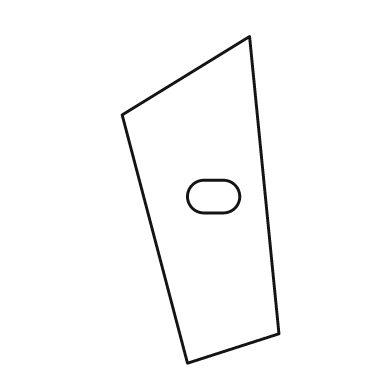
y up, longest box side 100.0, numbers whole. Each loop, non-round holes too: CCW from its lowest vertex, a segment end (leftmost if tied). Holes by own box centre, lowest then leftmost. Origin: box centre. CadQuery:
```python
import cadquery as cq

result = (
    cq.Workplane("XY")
    .moveTo(-4.0, -50.0)
    .lineTo(24.0, -41.0)
    .lineTo(15.0, 50.0)
    .lineTo(-24.0, 26.0)
    .close()
    .moveTo(1.0, -4.0)
    .lineTo(7.0, -4.0)
    .threePointArc((12.0, 1.0), (7.0, 6.0))
    .lineTo(1.0, 6.0)
    .threePointArc((-4.0, 1.0), (1.0, -4.0))
    .close()
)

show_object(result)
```